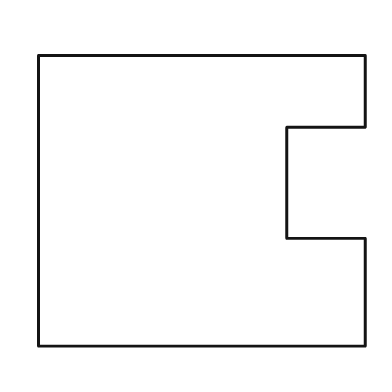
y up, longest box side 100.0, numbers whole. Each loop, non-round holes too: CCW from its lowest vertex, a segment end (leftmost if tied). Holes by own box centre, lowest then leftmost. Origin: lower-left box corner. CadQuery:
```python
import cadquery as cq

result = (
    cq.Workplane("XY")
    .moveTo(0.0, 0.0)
    .lineTo(100.0, 0.0)
    .lineTo(100.0, 33.0)
    .lineTo(76.0, 33.0)
    .lineTo(76.0, 67.0)
    .lineTo(100.0, 67.0)
    .lineTo(100.0, 89.0)
    .lineTo(0.0, 89.0)
    .close()
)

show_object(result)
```